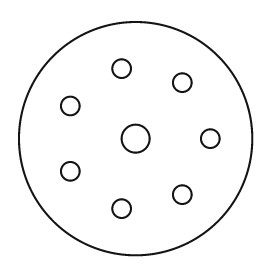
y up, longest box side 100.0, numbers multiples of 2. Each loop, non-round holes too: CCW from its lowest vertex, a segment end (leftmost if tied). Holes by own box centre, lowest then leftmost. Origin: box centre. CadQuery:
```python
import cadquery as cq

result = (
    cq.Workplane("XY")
    .moveTo(0.0, 0.0)
    .circle(50.0)
    .moveTo(-6.0, -30.0)
    .circle(4.0)
    .moveTo(20.0, -24.0)
    .circle(4.0)
    .moveTo(-28.0, -14.0)
    .circle(4.0)
    .moveTo(0.0, 0.0)
    .circle(6.0)
    .moveTo(32.0, 0.0)
    .circle(4.0)
    .moveTo(-28.0, 14.0)
    .circle(4.0)
    .moveTo(20.0, 24.0)
    .circle(4.0)
    .moveTo(-6.0, 30.0)
    .circle(4.0)
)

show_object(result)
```